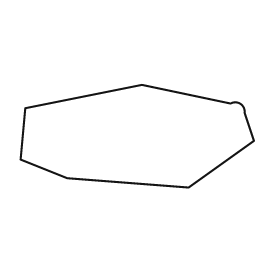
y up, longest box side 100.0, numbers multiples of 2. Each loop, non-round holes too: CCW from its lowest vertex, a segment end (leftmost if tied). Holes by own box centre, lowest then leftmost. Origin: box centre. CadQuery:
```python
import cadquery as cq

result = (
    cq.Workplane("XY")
    .moveTo(22.0, -22.0)
    .lineTo(50.0, -2.0)
    .lineTo(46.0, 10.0)
    .threePointArc((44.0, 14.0), (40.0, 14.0))
    .lineTo(2.0, 22.0)
    .lineTo(-48.0, 12.0)
    .lineTo(-50.0, -10.0)
    .lineTo(-30.0, -18.0)
    .close()
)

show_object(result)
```